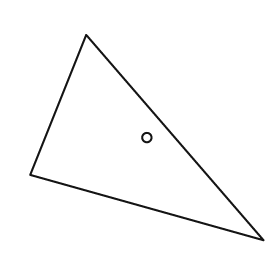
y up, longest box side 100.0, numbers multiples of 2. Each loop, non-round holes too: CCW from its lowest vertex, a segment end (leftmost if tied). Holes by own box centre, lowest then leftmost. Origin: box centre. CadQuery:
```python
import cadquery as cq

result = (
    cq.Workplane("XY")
    .moveTo(50.0, -44.0)
    .lineTo(-26.0, 44.0)
    .lineTo(-50.0, -16.0)
    .close()
    .moveTo(0.0, 0.0)
    .circle(2.0)
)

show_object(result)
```